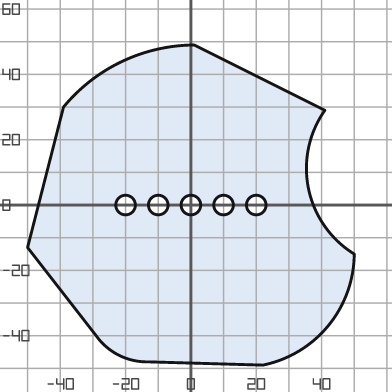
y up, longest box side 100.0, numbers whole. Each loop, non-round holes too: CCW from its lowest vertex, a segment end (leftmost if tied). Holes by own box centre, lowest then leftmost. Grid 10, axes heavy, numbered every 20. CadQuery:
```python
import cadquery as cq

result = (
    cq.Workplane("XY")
    .moveTo(22.0, -49.0)
    .threePointArc((42.0, -37.0), (50.0, -15.0))
    .threePointArc((36.0, 5.0), (41.0, 29.0))
    .lineTo(1.0, 49.0)
    .threePointArc((-21.0, 44.0), (-39.0, 30.0))
    .lineTo(-50.0, -13.0)
    .lineTo(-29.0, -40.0)
    .threePointArc((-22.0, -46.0), (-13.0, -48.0))
    .close()
    .moveTo(-20.0, 0.0)
    .circle(3.0)
    .moveTo(-10.0, 0.0)
    .circle(3.0)
    .moveTo(0.0, 0.0)
    .circle(3.0)
    .moveTo(10.0, 0.0)
    .circle(3.0)
    .moveTo(20.0, 0.0)
    .circle(3.0)
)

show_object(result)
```